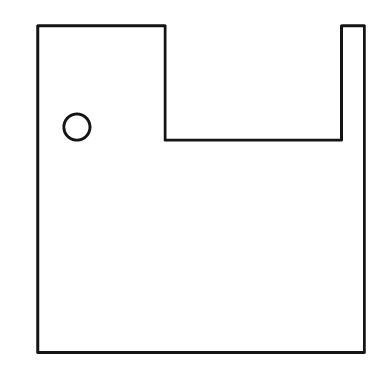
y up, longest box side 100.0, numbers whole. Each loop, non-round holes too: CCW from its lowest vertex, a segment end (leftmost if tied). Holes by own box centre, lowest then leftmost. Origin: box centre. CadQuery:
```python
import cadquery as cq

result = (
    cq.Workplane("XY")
    .moveTo(-50.0, -50.0)
    .lineTo(50.0, -50.0)
    .lineTo(50.0, 50.0)
    .lineTo(43.0, 50.0)
    .lineTo(43.0, 15.0)
    .lineTo(-11.0, 15.0)
    .lineTo(-11.0, 50.0)
    .lineTo(-50.0, 50.0)
    .close()
    .moveTo(-38.0, 19.0)
    .circle(4.0)
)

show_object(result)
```